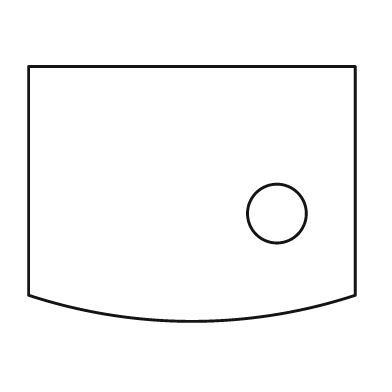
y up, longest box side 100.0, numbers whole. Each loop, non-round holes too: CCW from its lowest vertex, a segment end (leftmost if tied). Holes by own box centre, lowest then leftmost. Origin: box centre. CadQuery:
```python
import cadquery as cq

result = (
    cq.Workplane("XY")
    .moveTo(-50.0, -31.0)
    .threePointArc((0.0, -39.0), (50.0, -31.0))
    .lineTo(50.0, 39.0)
    .lineTo(-50.0, 39.0)
    .close()
    .moveTo(26.0, -6.0)
    .circle(9.0)
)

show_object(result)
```